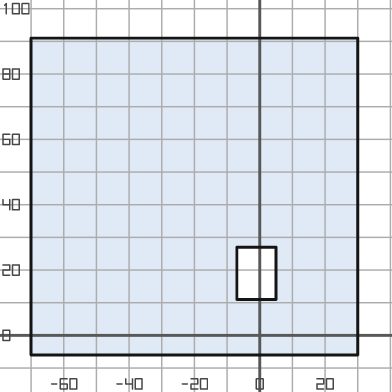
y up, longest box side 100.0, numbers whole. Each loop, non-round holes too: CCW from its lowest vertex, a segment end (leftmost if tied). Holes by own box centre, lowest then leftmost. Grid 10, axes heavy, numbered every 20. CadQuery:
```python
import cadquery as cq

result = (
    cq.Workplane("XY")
    .moveTo(-70.0, -6.0)
    .lineTo(30.0, -6.0)
    .lineTo(30.0, 91.0)
    .lineTo(-70.0, 91.0)
    .close()
    .moveTo(-7.0, 11.0)
    .lineTo(5.0, 11.0)
    .lineTo(5.0, 27.0)
    .lineTo(-7.0, 27.0)
    .close()
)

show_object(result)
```